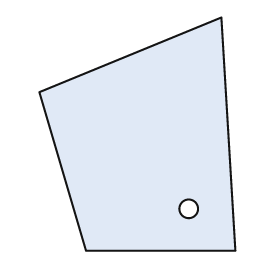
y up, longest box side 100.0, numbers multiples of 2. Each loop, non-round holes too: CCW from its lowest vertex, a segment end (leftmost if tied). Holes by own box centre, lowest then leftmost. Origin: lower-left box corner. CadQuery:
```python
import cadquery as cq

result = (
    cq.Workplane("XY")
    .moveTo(20.0, 0.0)
    .lineTo(84.0, 0.0)
    .lineTo(78.0, 100.0)
    .lineTo(0.0, 68.0)
    .close()
    .moveTo(64.0, 18.0)
    .circle(4.0)
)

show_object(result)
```